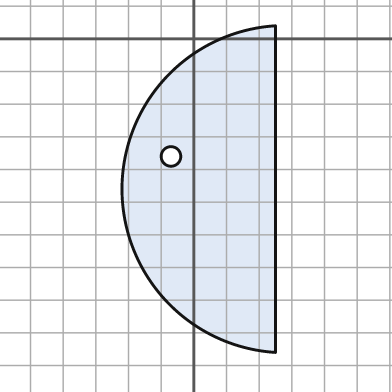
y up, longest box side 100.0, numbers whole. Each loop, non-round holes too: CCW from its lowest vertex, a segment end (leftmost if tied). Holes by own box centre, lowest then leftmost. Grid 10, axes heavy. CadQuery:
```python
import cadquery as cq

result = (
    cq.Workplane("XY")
    .moveTo(25.0, -96.0)
    .lineTo(25.0, 4.0)
    .threePointArc((-22.0, -46.0), (25.0, -96.0))
    .close()
    .moveTo(-7.0, -36.0)
    .circle(3.0)
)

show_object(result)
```